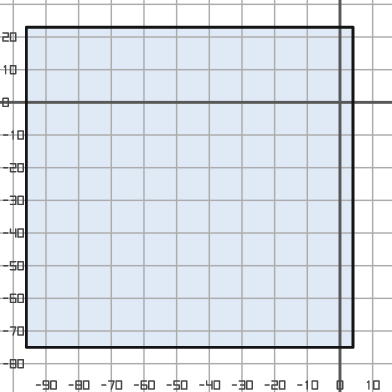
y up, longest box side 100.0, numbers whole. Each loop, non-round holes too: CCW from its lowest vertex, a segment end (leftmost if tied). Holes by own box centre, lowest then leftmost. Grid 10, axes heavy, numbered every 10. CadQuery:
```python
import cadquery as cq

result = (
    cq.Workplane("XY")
    .moveTo(-96.0, -75.0)
    .lineTo(4.0, -75.0)
    .lineTo(4.0, 23.0)
    .lineTo(-96.0, 23.0)
    .close()
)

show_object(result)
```